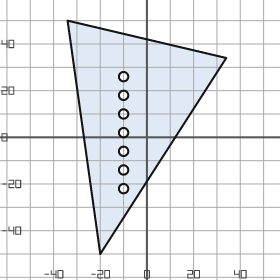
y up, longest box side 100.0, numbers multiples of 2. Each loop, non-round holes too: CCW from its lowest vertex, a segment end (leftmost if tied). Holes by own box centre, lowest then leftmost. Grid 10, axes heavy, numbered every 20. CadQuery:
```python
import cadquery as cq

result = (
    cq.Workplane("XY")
    .moveTo(-20.0, -50.0)
    .lineTo(34.0, 34.0)
    .lineTo(-34.0, 50.0)
    .close()
    .moveTo(-10.0, -22.0)
    .circle(2.0)
    .moveTo(-10.0, -14.0)
    .circle(2.0)
    .moveTo(-10.0, -6.0)
    .circle(2.0)
    .moveTo(-10.0, 2.0)
    .circle(2.0)
    .moveTo(-10.0, 10.0)
    .circle(2.0)
    .moveTo(-10.0, 18.0)
    .circle(2.0)
    .moveTo(-10.0, 26.0)
    .circle(2.0)
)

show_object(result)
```